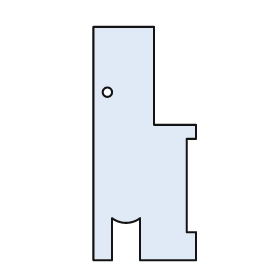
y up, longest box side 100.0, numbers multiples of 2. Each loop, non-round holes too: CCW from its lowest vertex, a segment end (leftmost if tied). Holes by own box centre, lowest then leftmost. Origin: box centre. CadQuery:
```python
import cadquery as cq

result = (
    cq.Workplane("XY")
    .moveTo(-22.0, -50.0)
    .lineTo(-14.0, -50.0)
    .lineTo(-14.0, -32.0)
    .threePointArc((-8.0, -34.0), (-2.0, -32.0))
    .lineTo(-2.0, -50.0)
    .lineTo(22.0, -50.0)
    .lineTo(22.0, -38.0)
    .lineTo(18.0, -38.0)
    .lineTo(18.0, 2.0)
    .lineTo(22.0, 2.0)
    .lineTo(22.0, 8.0)
    .lineTo(4.0, 8.0)
    .lineTo(4.0, 50.0)
    .lineTo(-22.0, 50.0)
    .close()
    .moveTo(-16.0, 22.0)
    .circle(2.0)
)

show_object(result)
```